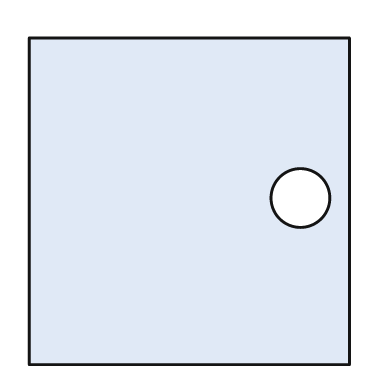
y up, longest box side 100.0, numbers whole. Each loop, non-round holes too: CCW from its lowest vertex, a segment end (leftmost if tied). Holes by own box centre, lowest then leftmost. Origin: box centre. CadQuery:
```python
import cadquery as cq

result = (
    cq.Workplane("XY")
    .moveTo(-49.0, -50.0)
    .lineTo(49.0, -50.0)
    .lineTo(49.0, 50.0)
    .lineTo(-49.0, 50.0)
    .close()
    .moveTo(34.0, 1.0)
    .circle(9.0)
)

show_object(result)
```